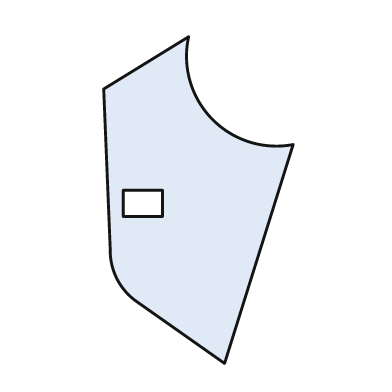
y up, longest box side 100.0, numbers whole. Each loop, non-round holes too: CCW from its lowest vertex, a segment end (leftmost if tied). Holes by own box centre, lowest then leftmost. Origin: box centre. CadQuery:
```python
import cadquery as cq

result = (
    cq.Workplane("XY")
    .moveTo(8.0, -50.0)
    .lineTo(29.0, 17.0)
    .threePointArc((4.0, 25.0), (-3.0, 50.0))
    .lineTo(-29.0, 34.0)
    .lineTo(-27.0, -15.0)
    .threePointArc((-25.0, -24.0), (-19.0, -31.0))
    .close()
    .moveTo(-23.0, -5.0)
    .lineTo(-11.0, -5.0)
    .lineTo(-11.0, 3.0)
    .lineTo(-23.0, 3.0)
    .close()
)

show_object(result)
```